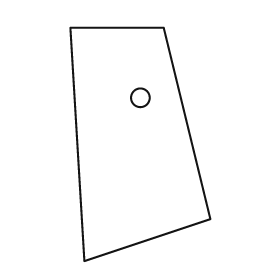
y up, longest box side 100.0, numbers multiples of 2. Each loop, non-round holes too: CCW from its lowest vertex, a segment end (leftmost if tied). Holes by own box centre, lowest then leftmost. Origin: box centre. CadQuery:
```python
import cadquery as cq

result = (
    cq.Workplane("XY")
    .moveTo(-24.0, -50.0)
    .lineTo(30.0, -32.0)
    .lineTo(10.0, 50.0)
    .lineTo(-30.0, 50.0)
    .close()
    .moveTo(0.0, 20.0)
    .circle(4.0)
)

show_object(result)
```